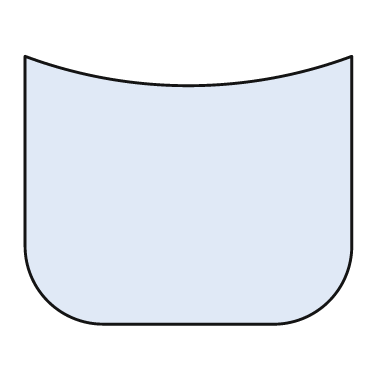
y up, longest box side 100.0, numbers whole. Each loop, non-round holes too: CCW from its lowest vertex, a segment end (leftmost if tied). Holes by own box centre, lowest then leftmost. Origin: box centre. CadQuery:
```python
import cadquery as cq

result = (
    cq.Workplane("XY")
    .moveTo(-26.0, -41.0)
    .lineTo(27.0, -41.0)
    .threePointArc((43.0, -34.0), (50.0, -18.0))
    .lineTo(50.0, 41.0)
    .threePointArc((0.0, 32.0), (-50.0, 41.0))
    .lineTo(-50.0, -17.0)
    .threePointArc((-43.0, -34.0), (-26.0, -41.0))
    .close()
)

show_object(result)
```